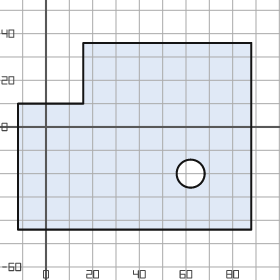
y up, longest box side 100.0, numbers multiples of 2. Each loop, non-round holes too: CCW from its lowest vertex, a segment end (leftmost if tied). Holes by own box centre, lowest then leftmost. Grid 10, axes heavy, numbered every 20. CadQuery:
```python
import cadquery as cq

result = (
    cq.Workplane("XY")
    .moveTo(-12.0, -44.0)
    .lineTo(88.0, -44.0)
    .lineTo(88.0, 36.0)
    .lineTo(16.0, 36.0)
    .lineTo(16.0, 10.0)
    .lineTo(-12.0, 10.0)
    .close()
    .moveTo(62.0, -20.0)
    .circle(6.0)
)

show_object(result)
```